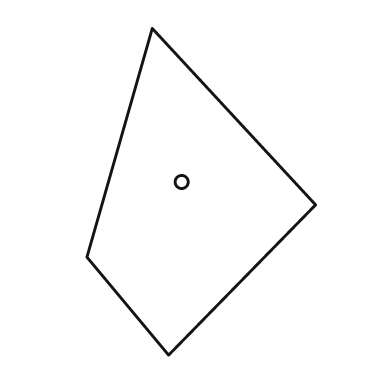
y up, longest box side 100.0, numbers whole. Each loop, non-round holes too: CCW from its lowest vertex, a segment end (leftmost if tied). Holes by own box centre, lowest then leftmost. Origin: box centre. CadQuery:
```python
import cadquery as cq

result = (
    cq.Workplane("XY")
    .moveTo(-10.0, -50.0)
    .lineTo(35.0, -4.0)
    .lineTo(-15.0, 50.0)
    .lineTo(-35.0, -20.0)
    .close()
    .moveTo(-6.0, 3.0)
    .circle(2.0)
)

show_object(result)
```